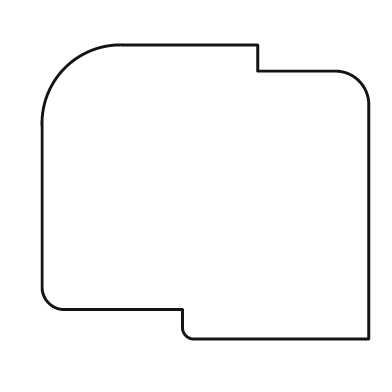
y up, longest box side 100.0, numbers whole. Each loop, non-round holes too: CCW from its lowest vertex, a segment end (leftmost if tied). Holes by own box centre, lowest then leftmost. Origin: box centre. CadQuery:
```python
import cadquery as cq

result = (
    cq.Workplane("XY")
    .moveTo(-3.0, -45.0)
    .lineTo(50.0, -45.0)
    .lineTo(50.0, 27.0)
    .threePointArc((47.0, 34.0), (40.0, 37.0))
    .lineTo(16.0, 37.0)
    .lineTo(16.0, 45.0)
    .lineTo(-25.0, 45.0)
    .threePointArc((-43.0, 38.0), (-50.0, 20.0))
    .lineTo(-50.0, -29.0)
    .threePointArc((-48.0, -34.0), (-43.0, -36.0))
    .lineTo(-7.0, -36.0)
    .lineTo(-7.0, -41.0)
    .threePointArc((-6.0, -44.0), (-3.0, -45.0))
    .close()
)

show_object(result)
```